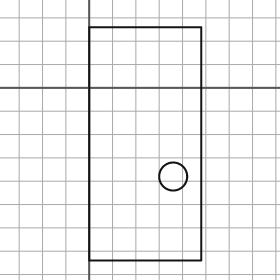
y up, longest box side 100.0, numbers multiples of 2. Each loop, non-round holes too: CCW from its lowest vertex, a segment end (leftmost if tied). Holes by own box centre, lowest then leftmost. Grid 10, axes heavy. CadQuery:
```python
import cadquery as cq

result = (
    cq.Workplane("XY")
    .moveTo(0.0, -74.0)
    .lineTo(48.0, -74.0)
    .lineTo(48.0, 26.0)
    .lineTo(0.0, 26.0)
    .close()
    .moveTo(36.0, -38.0)
    .circle(6.0)
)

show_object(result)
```